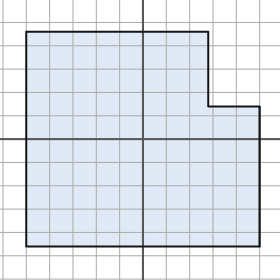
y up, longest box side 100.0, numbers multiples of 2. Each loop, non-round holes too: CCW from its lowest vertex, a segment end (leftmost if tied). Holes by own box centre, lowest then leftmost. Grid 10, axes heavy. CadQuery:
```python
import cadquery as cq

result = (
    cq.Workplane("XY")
    .moveTo(-50.0, -46.0)
    .lineTo(50.0, -46.0)
    .lineTo(50.0, 14.0)
    .lineTo(28.0, 14.0)
    .lineTo(28.0, 46.0)
    .lineTo(-50.0, 46.0)
    .close()
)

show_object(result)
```